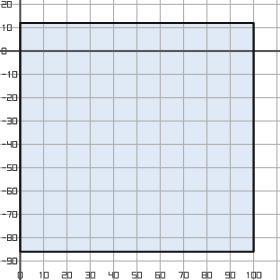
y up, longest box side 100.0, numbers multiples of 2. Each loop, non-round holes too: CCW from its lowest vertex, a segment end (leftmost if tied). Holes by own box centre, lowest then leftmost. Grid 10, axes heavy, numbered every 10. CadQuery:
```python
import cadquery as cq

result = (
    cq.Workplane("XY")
    .moveTo(0.0, -86.0)
    .lineTo(100.0, -86.0)
    .lineTo(100.0, 12.0)
    .lineTo(0.0, 12.0)
    .close()
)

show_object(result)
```